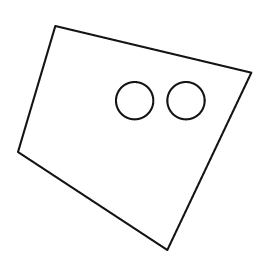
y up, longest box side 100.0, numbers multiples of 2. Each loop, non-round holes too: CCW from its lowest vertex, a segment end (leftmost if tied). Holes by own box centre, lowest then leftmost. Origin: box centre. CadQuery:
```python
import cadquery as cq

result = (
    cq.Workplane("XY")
    .moveTo(14.0, -48.0)
    .lineTo(50.0, 28.0)
    .lineTo(-34.0, 48.0)
    .lineTo(-50.0, -6.0)
    .close()
    .moveTo(0.0, 16.0)
    .circle(8.0)
    .moveTo(22.0, 16.0)
    .circle(8.0)
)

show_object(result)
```